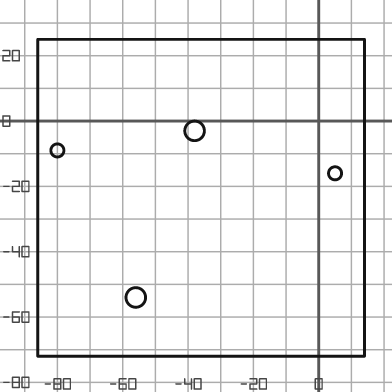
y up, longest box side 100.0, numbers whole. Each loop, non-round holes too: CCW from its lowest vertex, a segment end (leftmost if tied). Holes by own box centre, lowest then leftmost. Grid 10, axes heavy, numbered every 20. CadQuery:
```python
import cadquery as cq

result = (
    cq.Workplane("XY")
    .moveTo(-86.0, -72.0)
    .lineTo(14.0, -72.0)
    .lineTo(14.0, 25.0)
    .lineTo(-86.0, 25.0)
    .close()
    .moveTo(-56.0, -54.0)
    .circle(3.0)
    .moveTo(5.0, -16.0)
    .circle(2.0)
    .moveTo(-80.0, -9.0)
    .circle(2.0)
    .moveTo(-38.0, -3.0)
    .circle(3.0)
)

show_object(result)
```